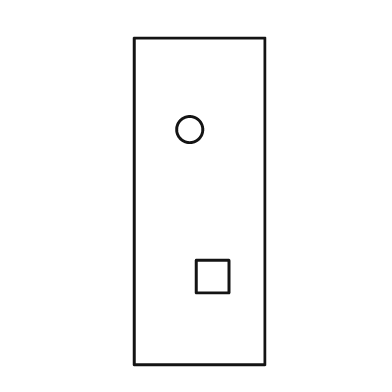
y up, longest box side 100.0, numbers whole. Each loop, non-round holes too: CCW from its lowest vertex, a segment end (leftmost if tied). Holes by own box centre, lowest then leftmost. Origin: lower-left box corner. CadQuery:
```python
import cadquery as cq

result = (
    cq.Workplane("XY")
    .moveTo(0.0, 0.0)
    .lineTo(40.0, 0.0)
    .lineTo(40.0, 100.0)
    .lineTo(0.0, 100.0)
    .close()
    .moveTo(19.0, 22.0)
    .lineTo(29.0, 22.0)
    .lineTo(29.0, 32.0)
    .lineTo(19.0, 32.0)
    .close()
    .moveTo(17.0, 72.0)
    .circle(4.0)
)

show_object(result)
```